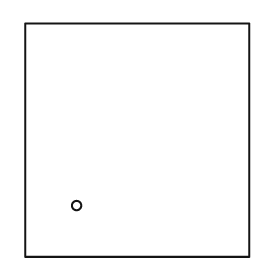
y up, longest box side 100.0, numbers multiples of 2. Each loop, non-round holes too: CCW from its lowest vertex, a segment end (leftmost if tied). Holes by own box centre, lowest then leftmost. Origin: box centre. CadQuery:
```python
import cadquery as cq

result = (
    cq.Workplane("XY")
    .moveTo(-48.0, -50.0)
    .lineTo(48.0, -50.0)
    .lineTo(48.0, 50.0)
    .lineTo(-48.0, 50.0)
    .close()
    .moveTo(-26.0, -28.0)
    .circle(2.0)
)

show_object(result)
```